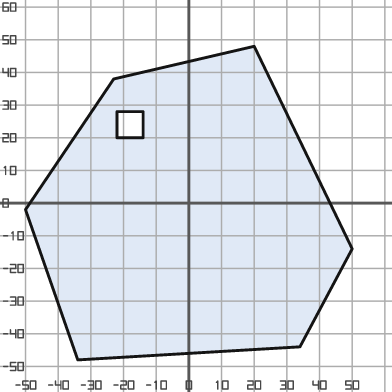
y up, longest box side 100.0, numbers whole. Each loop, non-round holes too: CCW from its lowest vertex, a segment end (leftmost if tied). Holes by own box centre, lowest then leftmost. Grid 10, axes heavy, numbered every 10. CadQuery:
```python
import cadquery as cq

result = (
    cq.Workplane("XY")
    .moveTo(-34.0, -48.0)
    .lineTo(34.0, -44.0)
    .lineTo(50.0, -14.0)
    .lineTo(20.0, 48.0)
    .lineTo(-23.0, 38.0)
    .lineTo(-50.0, -2.0)
    .close()
    .moveTo(-22.0, 20.0)
    .lineTo(-14.0, 20.0)
    .lineTo(-14.0, 28.0)
    .lineTo(-22.0, 28.0)
    .close()
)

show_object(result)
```